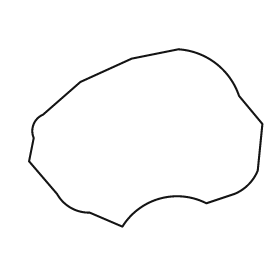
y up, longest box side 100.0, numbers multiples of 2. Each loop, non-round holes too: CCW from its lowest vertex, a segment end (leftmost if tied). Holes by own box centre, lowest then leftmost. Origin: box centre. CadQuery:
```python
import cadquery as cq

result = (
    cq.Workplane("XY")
    .moveTo(-10.0, -38.0)
    .threePointArc((6.0, -26.0), (26.0, -28.0))
    .lineTo(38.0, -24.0)
    .threePointArc((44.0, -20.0), (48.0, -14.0))
    .lineTo(50.0, 6.0)
    .lineTo(40.0, 18.0)
    .threePointArc((30.0, 32.0), (14.0, 38.0))
    .lineTo(-6.0, 34.0)
    .lineTo(-28.0, 24.0)
    .lineTo(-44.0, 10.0)
    .threePointArc((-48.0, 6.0), (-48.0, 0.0))
    .lineTo(-50.0, -10.0)
    .lineTo(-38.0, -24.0)
    .threePointArc((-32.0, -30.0), (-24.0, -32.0))
    .close()
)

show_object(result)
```